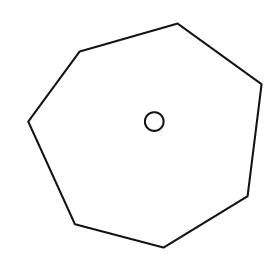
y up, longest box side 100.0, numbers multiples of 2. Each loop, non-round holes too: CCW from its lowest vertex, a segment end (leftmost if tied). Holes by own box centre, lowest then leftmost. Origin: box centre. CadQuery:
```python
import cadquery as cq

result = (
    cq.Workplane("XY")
    .moveTo(8.0, -48.0)
    .lineTo(44.0, -26.0)
    .lineTo(50.0, 22.0)
    .lineTo(14.0, 48.0)
    .lineTo(-28.0, 36.0)
    .lineTo(-50.0, 6.0)
    .lineTo(-30.0, -38.0)
    .close()
    .moveTo(4.0, 6.0)
    .circle(4.0)
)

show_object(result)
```